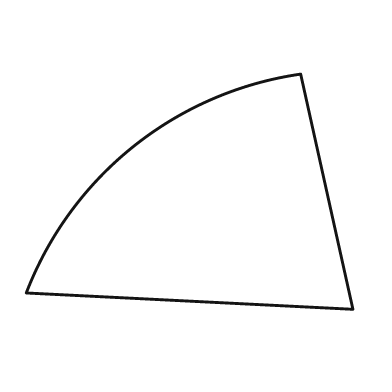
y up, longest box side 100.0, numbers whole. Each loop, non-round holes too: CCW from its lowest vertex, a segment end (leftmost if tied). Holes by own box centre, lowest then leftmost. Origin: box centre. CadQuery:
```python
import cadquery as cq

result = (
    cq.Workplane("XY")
    .moveTo(50.0, -36.0)
    .lineTo(34.0, 36.0)
    .threePointArc((-17.0, 14.0), (-50.0, -31.0))
    .close()
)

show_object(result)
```